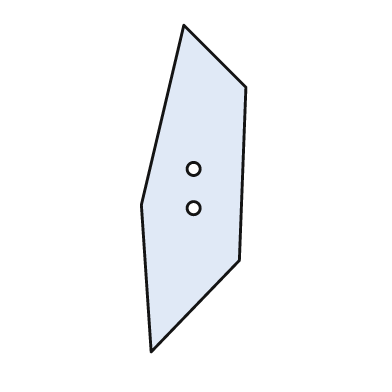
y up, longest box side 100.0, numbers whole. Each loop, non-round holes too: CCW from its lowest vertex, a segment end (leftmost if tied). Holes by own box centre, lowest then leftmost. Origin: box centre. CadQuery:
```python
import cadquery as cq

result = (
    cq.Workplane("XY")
    .moveTo(-13.0, -50.0)
    .lineTo(14.0, -22.0)
    .lineTo(16.0, 31.0)
    .lineTo(-3.0, 50.0)
    .lineTo(-16.0, -5.0)
    .close()
    .moveTo(0.0, -6.0)
    .circle(2.0)
    .moveTo(0.0, 6.0)
    .circle(2.0)
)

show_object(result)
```